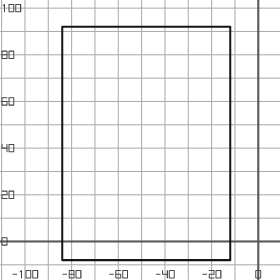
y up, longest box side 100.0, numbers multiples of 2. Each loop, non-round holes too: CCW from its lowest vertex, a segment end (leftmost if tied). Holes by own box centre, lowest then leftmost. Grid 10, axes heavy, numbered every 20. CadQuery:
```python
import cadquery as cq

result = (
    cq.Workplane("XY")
    .moveTo(-84.0, -8.0)
    .lineTo(-12.0, -8.0)
    .lineTo(-12.0, 92.0)
    .lineTo(-84.0, 92.0)
    .close()
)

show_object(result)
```